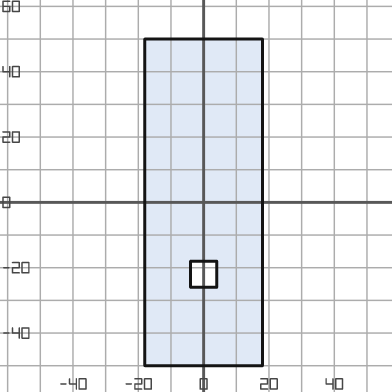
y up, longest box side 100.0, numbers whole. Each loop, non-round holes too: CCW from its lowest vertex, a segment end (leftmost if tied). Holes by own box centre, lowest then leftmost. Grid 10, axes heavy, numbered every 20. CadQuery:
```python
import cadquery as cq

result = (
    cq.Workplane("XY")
    .moveTo(-18.0, -50.0)
    .lineTo(18.0, -50.0)
    .lineTo(18.0, 50.0)
    .lineTo(-18.0, 50.0)
    .close()
    .moveTo(-4.0, -26.0)
    .lineTo(4.0, -26.0)
    .lineTo(4.0, -18.0)
    .lineTo(-4.0, -18.0)
    .close()
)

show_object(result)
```